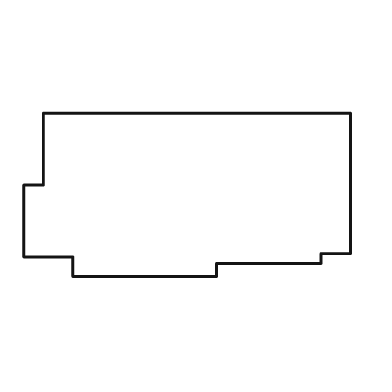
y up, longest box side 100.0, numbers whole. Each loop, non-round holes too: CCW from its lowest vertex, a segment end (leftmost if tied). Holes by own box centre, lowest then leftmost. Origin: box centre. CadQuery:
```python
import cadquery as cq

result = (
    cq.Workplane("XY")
    .moveTo(-35.0, -25.0)
    .lineTo(9.0, -25.0)
    .lineTo(9.0, -21.0)
    .lineTo(41.0, -21.0)
    .lineTo(41.0, -18.0)
    .lineTo(50.0, -18.0)
    .lineTo(50.0, 25.0)
    .lineTo(-44.0, 25.0)
    .lineTo(-44.0, 3.0)
    .lineTo(-50.0, 3.0)
    .lineTo(-50.0, -19.0)
    .lineTo(-35.0, -19.0)
    .close()
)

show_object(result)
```